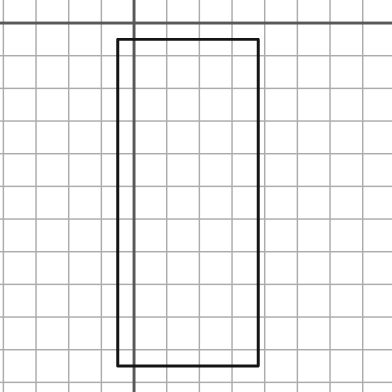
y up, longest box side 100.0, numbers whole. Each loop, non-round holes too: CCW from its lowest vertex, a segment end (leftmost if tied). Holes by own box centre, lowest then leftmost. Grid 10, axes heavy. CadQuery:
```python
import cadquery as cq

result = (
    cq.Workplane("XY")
    .moveTo(-5.0, -105.0)
    .lineTo(38.0, -105.0)
    .lineTo(38.0, -5.0)
    .lineTo(-5.0, -5.0)
    .close()
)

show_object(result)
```